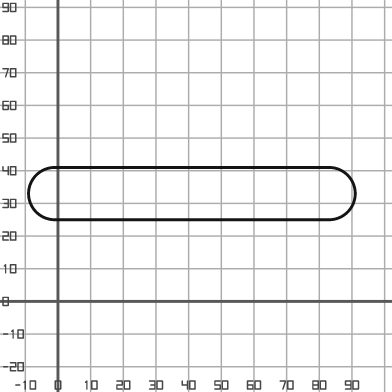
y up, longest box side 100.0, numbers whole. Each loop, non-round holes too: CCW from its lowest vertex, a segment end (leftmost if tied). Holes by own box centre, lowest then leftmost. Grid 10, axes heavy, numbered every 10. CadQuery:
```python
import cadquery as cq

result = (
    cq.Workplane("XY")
    .moveTo(-1.0, 25.0)
    .lineTo(83.0, 25.0)
    .threePointArc((91.0, 33.0), (83.0, 41.0))
    .lineTo(-1.0, 41.0)
    .threePointArc((-9.0, 33.0), (-1.0, 25.0))
    .close()
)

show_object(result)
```